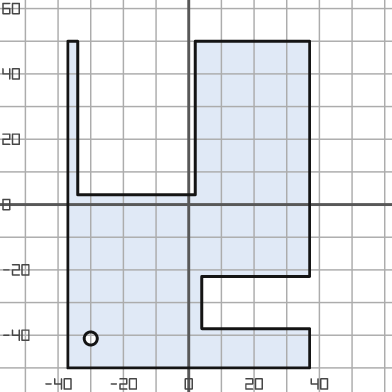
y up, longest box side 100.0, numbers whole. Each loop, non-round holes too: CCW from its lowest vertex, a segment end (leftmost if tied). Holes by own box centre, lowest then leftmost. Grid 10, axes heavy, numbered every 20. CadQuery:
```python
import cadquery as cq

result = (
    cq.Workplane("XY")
    .moveTo(-37.0, -50.0)
    .lineTo(37.0, -50.0)
    .lineTo(37.0, -38.0)
    .lineTo(4.0, -38.0)
    .lineTo(4.0, -22.0)
    .lineTo(37.0, -22.0)
    .lineTo(37.0, 50.0)
    .lineTo(2.0, 50.0)
    .lineTo(2.0, 3.0)
    .lineTo(-34.0, 3.0)
    .lineTo(-34.0, 50.0)
    .lineTo(-37.0, 50.0)
    .close()
    .moveTo(-30.0, -41.0)
    .circle(2.0)
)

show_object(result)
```